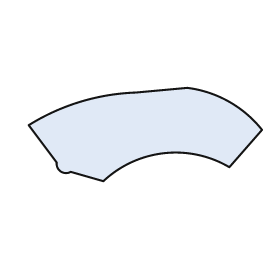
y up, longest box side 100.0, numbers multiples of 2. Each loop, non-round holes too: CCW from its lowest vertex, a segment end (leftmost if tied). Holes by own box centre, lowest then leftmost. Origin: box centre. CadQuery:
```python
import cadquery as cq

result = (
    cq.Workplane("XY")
    .moveTo(-18.0, -20.0)
    .threePointArc((8.0, -8.0), (36.0, -14.0))
    .lineTo(50.0, 2.0)
    .threePointArc((36.0, 14.0), (18.0, 20.0))
    .lineTo(-4.0, 18.0)
    .threePointArc((-28.0, 14.0), (-50.0, 4.0))
    .lineTo(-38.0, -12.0)
    .threePointArc((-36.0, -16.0), (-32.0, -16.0))
    .close()
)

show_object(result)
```